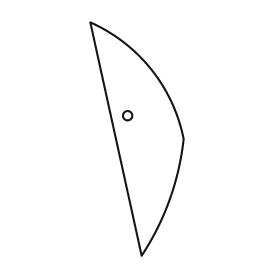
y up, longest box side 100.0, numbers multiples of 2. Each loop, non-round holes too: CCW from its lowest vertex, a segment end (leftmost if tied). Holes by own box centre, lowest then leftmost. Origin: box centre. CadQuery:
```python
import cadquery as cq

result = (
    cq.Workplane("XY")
    .moveTo(2.0, -50.0)
    .threePointArc((14.0, -26.0), (20.0, 0.0))
    .threePointArc((6.0, 30.0), (-20.0, 50.0))
    .close()
    .moveTo(-4.0, 10.0)
    .circle(2.0)
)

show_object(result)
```